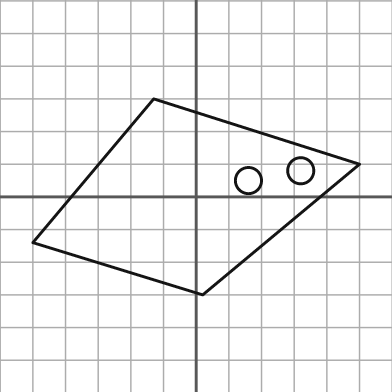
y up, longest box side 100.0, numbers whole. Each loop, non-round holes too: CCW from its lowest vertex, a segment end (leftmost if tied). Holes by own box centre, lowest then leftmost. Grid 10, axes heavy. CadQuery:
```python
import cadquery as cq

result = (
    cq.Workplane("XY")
    .moveTo(2.0, -30.0)
    .lineTo(50.0, 10.0)
    .lineTo(-13.0, 30.0)
    .lineTo(-50.0, -14.0)
    .close()
    .moveTo(16.0, 5.0)
    .circle(4.0)
    .moveTo(32.0, 8.0)
    .circle(4.0)
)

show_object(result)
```